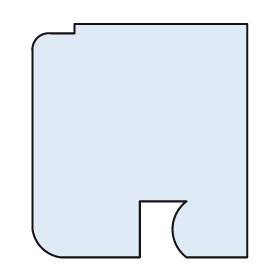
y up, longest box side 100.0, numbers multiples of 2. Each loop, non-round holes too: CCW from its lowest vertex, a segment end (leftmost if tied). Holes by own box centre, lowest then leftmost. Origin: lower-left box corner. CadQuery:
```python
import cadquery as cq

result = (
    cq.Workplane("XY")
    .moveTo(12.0, 0.0)
    .lineTo(46.0, 0.0)
    .lineTo(46.0, 24.0)
    .lineTo(66.0, 24.0)
    .threePointArc((60.0, 12.0), (66.0, 0.0))
    .lineTo(92.0, 0.0)
    .lineTo(92.0, 100.0)
    .lineTo(18.0, 100.0)
    .lineTo(18.0, 96.0)
    .lineTo(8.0, 96.0)
    .threePointArc((2.0, 94.0), (0.0, 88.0))
    .lineTo(0.0, 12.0)
    .threePointArc((4.0, 4.0), (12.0, 0.0))
    .close()
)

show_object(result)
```